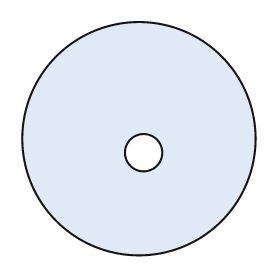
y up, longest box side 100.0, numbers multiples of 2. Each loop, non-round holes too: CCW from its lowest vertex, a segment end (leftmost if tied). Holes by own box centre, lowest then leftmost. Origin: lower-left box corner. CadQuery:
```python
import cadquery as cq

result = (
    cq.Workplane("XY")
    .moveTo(50.0, 50.0)
    .circle(50.0)
    .moveTo(52.0, 44.0)
    .circle(8.0)
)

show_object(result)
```